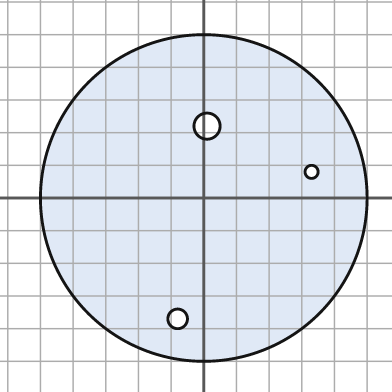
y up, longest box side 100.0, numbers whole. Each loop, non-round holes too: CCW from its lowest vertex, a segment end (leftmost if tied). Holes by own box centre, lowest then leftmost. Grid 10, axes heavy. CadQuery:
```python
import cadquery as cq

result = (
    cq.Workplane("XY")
    .moveTo(0.0, 0.0)
    .circle(50.0)
    .moveTo(-8.0, -37.0)
    .circle(3.0)
    .moveTo(33.0, 8.0)
    .circle(2.0)
    .moveTo(1.0, 22.0)
    .circle(4.0)
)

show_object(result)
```